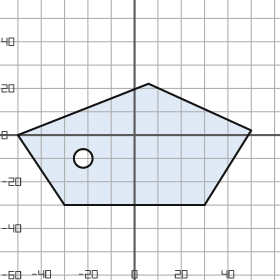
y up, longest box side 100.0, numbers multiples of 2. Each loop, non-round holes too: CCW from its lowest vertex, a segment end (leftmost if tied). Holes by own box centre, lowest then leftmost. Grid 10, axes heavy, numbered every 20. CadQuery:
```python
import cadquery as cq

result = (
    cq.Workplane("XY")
    .moveTo(-30.0, -30.0)
    .lineTo(30.0, -30.0)
    .lineTo(50.0, 2.0)
    .lineTo(6.0, 22.0)
    .lineTo(-50.0, 0.0)
    .close()
    .moveTo(-22.0, -10.0)
    .circle(4.0)
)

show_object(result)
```